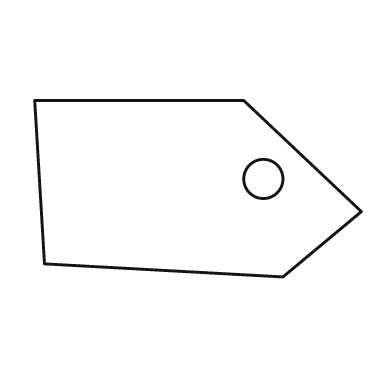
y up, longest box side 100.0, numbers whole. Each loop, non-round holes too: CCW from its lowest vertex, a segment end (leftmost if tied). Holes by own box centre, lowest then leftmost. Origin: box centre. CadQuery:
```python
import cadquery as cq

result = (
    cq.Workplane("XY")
    .moveTo(26.0, -27.0)
    .lineTo(50.0, -7.0)
    .lineTo(14.0, 27.0)
    .lineTo(-50.0, 27.0)
    .lineTo(-47.0, -23.0)
    .close()
    .moveTo(20.0, 3.0)
    .circle(6.0)
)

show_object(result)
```